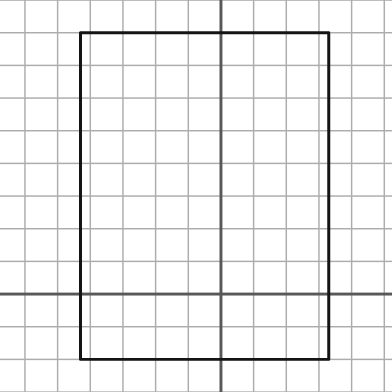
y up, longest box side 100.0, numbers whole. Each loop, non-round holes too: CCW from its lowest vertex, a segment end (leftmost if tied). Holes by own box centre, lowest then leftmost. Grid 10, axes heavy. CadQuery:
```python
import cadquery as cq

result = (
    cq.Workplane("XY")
    .moveTo(-43.0, -20.0)
    .lineTo(33.0, -20.0)
    .lineTo(33.0, 80.0)
    .lineTo(-43.0, 80.0)
    .close()
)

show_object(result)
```